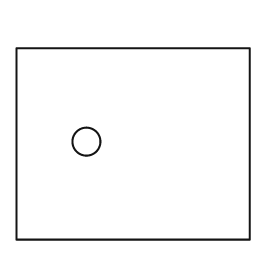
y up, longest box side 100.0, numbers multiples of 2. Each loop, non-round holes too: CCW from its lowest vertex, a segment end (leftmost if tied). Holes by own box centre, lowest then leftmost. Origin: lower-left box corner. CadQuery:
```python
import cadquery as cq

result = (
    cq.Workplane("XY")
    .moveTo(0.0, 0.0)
    .lineTo(100.0, 0.0)
    .lineTo(100.0, 82.0)
    .lineTo(0.0, 82.0)
    .close()
    .moveTo(30.0, 42.0)
    .circle(6.0)
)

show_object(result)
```